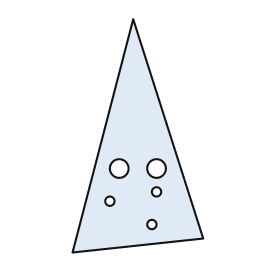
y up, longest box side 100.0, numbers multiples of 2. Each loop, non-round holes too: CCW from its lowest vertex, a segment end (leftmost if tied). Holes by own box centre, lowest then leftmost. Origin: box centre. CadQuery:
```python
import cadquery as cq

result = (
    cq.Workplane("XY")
    .moveTo(-28.0, -50.0)
    .lineTo(28.0, -44.0)
    .lineTo(-2.0, 50.0)
    .close()
    .moveTo(6.0, -38.0)
    .circle(2.0)
    .moveTo(-12.0, -28.0)
    .circle(2.0)
    .moveTo(8.0, -24.0)
    .circle(2.0)
    .moveTo(-8.0, -14.0)
    .circle(4.0)
    .moveTo(8.0, -14.0)
    .circle(4.0)
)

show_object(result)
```